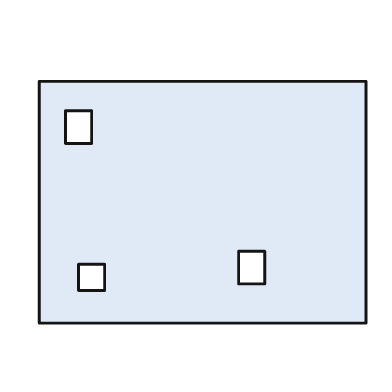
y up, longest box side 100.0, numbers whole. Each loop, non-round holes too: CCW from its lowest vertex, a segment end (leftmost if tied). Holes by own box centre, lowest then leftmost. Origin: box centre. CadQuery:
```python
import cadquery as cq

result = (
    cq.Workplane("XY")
    .moveTo(-50.0, -37.0)
    .lineTo(50.0, -37.0)
    .lineTo(50.0, 37.0)
    .lineTo(-50.0, 37.0)
    .close()
    .moveTo(-38.0, -27.0)
    .lineTo(-30.0, -27.0)
    .lineTo(-30.0, -19.0)
    .lineTo(-38.0, -19.0)
    .close()
    .moveTo(11.0, -25.0)
    .lineTo(19.0, -25.0)
    .lineTo(19.0, -15.0)
    .lineTo(11.0, -15.0)
    .close()
    .moveTo(-42.0, 18.0)
    .lineTo(-34.0, 18.0)
    .lineTo(-34.0, 28.0)
    .lineTo(-42.0, 28.0)
    .close()
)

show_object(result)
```